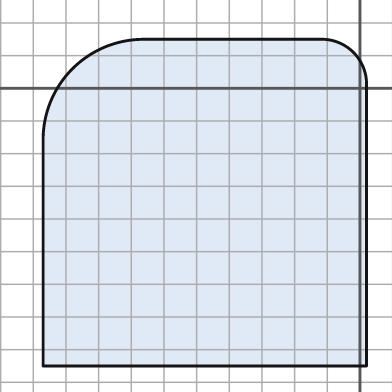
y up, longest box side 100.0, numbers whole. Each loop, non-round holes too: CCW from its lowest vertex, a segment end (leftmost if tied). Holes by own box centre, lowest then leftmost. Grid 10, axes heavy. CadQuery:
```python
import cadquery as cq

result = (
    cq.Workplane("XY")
    .moveTo(-97.0, -85.0)
    .lineTo(2.0, -85.0)
    .lineTo(2.0, 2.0)
    .threePointArc((-2.0, 11.0), (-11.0, 15.0))
    .lineTo(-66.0, 15.0)
    .threePointArc((-88.0, 6.0), (-97.0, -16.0))
    .close()
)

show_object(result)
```